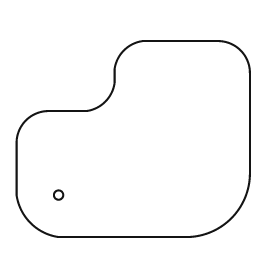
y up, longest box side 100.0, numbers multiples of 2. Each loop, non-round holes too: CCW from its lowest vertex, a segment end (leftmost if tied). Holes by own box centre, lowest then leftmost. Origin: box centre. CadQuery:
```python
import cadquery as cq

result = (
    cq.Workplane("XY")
    .moveTo(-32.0, -42.0)
    .lineTo(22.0, -42.0)
    .threePointArc((42.0, -34.0), (50.0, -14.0))
    .lineTo(50.0, 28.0)
    .threePointArc((46.0, 38.0), (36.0, 42.0))
    .lineTo(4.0, 42.0)
    .threePointArc((-4.0, 38.0), (-8.0, 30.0))
    .lineTo(-8.0, 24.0)
    .threePointArc((-12.0, 16.0), (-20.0, 12.0))
    .lineTo(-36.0, 12.0)
    .threePointArc((-46.0, 8.0), (-50.0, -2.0))
    .lineTo(-50.0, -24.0)
    .threePointArc((-44.0, -36.0), (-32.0, -42.0))
    .close()
    .moveTo(-32.0, -24.0)
    .circle(2.0)
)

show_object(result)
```